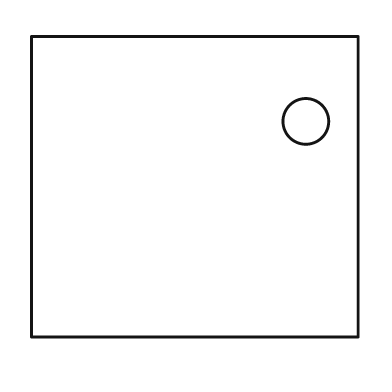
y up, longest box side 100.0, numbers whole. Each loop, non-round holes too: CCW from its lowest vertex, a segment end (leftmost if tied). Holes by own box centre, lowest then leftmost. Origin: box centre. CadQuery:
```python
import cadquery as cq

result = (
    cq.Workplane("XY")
    .moveTo(-50.0, -46.0)
    .lineTo(50.0, -46.0)
    .lineTo(50.0, 46.0)
    .lineTo(-50.0, 46.0)
    .close()
    .moveTo(34.0, 20.0)
    .circle(7.0)
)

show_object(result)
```